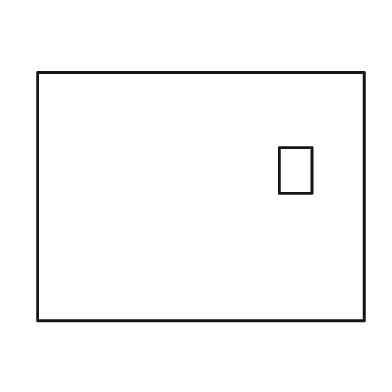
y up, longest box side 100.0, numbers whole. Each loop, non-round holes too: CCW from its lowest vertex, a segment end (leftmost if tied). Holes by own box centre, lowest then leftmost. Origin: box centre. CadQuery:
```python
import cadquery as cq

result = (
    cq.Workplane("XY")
    .moveTo(-50.0, -38.0)
    .lineTo(50.0, -38.0)
    .lineTo(50.0, 38.0)
    .lineTo(-50.0, 38.0)
    .close()
    .moveTo(24.0, 1.0)
    .lineTo(34.0, 1.0)
    .lineTo(34.0, 15.0)
    .lineTo(24.0, 15.0)
    .close()
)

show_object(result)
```